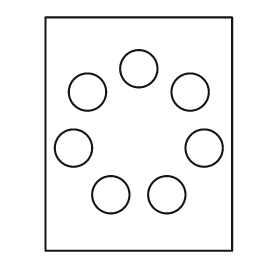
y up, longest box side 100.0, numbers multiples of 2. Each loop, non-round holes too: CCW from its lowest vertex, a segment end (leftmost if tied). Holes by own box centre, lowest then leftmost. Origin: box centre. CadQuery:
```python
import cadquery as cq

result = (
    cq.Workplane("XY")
    .moveTo(-40.0, -50.0)
    .lineTo(40.0, -50.0)
    .lineTo(40.0, 50.0)
    .lineTo(-40.0, 50.0)
    .close()
    .moveTo(-12.0, -26.0)
    .circle(8.0)
    .moveTo(12.0, -26.0)
    .circle(8.0)
    .moveTo(-28.0, -6.0)
    .circle(8.0)
    .moveTo(28.0, -6.0)
    .circle(8.0)
    .moveTo(-22.0, 18.0)
    .circle(8.0)
    .moveTo(22.0, 18.0)
    .circle(8.0)
    .moveTo(0.0, 28.0)
    .circle(8.0)
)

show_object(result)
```